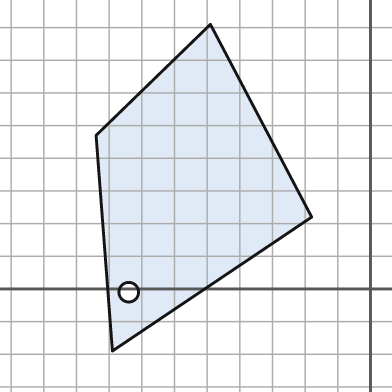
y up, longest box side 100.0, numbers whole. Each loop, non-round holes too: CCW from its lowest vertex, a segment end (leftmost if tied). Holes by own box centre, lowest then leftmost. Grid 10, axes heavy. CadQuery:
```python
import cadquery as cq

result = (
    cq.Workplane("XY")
    .moveTo(-79.0, -19.0)
    .lineTo(-18.0, 22.0)
    .lineTo(-49.0, 81.0)
    .lineTo(-84.0, 47.0)
    .close()
    .moveTo(-74.0, -1.0)
    .circle(3.0)
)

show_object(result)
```